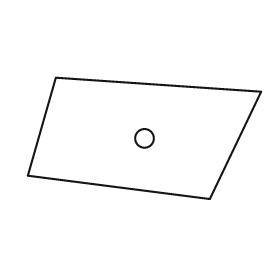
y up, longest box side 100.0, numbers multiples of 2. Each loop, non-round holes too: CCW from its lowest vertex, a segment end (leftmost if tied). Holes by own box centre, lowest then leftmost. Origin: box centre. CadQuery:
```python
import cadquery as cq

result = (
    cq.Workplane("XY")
    .moveTo(28.0, -26.0)
    .lineTo(50.0, 20.0)
    .lineTo(-38.0, 26.0)
    .lineTo(-50.0, -16.0)
    .close()
    .moveTo(0.0, 0.0)
    .circle(4.0)
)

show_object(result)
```